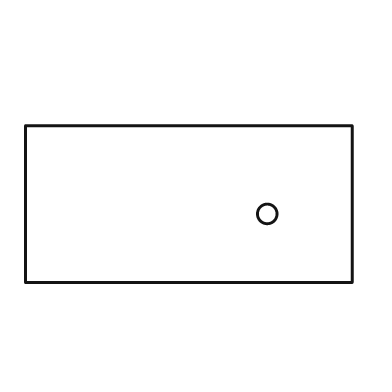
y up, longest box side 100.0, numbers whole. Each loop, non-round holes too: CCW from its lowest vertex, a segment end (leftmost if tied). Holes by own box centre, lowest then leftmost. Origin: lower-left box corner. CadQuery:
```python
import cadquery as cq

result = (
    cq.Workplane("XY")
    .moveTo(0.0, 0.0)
    .lineTo(100.0, 0.0)
    .lineTo(100.0, 48.0)
    .lineTo(0.0, 48.0)
    .close()
    .moveTo(74.0, 21.0)
    .circle(3.0)
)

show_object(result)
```